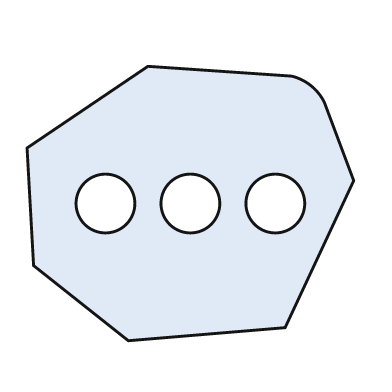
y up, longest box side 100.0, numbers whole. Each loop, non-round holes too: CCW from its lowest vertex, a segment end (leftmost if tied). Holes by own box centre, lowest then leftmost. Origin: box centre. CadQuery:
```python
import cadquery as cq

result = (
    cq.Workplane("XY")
    .moveTo(-19.0, -42.0)
    .lineTo(29.0, -38.0)
    .lineTo(50.0, 7.0)
    .lineTo(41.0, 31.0)
    .threePointArc((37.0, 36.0), (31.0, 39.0))
    .lineTo(-13.0, 42.0)
    .lineTo(-50.0, 17.0)
    .lineTo(-48.0, -19.0)
    .close()
    .moveTo(-26.0, 0.0)
    .circle(9.0)
    .moveTo(0.0, 0.0)
    .circle(9.0)
    .moveTo(26.0, 0.0)
    .circle(9.0)
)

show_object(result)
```